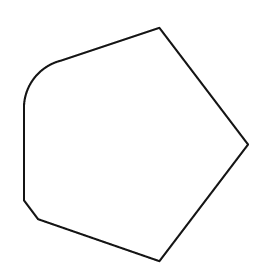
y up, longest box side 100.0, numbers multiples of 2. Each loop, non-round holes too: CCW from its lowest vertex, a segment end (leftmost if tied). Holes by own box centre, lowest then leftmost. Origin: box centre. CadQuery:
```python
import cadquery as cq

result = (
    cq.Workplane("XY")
    .moveTo(10.0, -50.0)
    .lineTo(48.0, 0.0)
    .lineTo(10.0, 50.0)
    .lineTo(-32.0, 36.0)
    .threePointArc((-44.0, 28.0), (-48.0, 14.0))
    .lineTo(-48.0, -24.0)
    .lineTo(-42.0, -32.0)
    .close()
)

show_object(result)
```